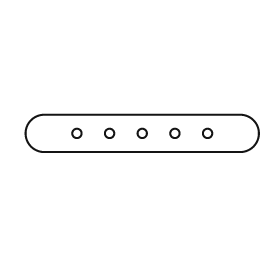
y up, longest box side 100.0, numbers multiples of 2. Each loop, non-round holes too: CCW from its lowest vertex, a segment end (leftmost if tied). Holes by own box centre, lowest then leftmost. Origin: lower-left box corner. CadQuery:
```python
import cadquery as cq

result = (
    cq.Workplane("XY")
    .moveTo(8.0, 0.0)
    .lineTo(92.0, 0.0)
    .threePointArc((100.0, 8.0), (92.0, 16.0))
    .lineTo(8.0, 16.0)
    .threePointArc((0.0, 8.0), (8.0, 0.0))
    .close()
    .moveTo(22.0, 8.0)
    .circle(2.0)
    .moveTo(36.0, 8.0)
    .circle(2.0)
    .moveTo(50.0, 8.0)
    .circle(2.0)
    .moveTo(64.0, 8.0)
    .circle(2.0)
    .moveTo(78.0, 8.0)
    .circle(2.0)
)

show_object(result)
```